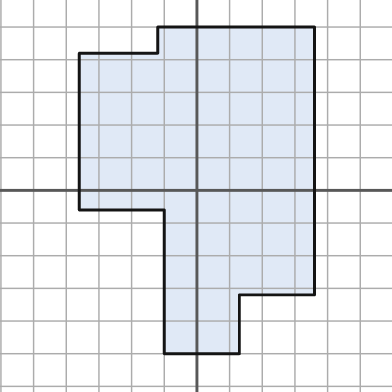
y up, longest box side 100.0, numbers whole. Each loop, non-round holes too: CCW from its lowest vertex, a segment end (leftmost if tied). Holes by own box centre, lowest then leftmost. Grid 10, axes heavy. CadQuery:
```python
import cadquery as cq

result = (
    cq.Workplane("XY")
    .moveTo(-10.0, -50.0)
    .lineTo(13.0, -50.0)
    .lineTo(13.0, -32.0)
    .lineTo(36.0, -32.0)
    .lineTo(36.0, 50.0)
    .lineTo(-12.0, 50.0)
    .lineTo(-12.0, 42.0)
    .lineTo(-36.0, 42.0)
    .lineTo(-36.0, -6.0)
    .lineTo(-10.0, -6.0)
    .close()
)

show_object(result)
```